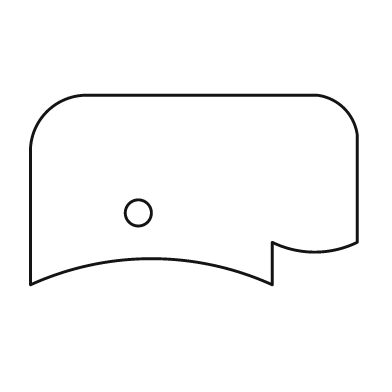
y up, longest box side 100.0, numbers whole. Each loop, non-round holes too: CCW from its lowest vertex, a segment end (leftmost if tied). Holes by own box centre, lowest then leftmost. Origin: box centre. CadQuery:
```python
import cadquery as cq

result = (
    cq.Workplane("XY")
    .moveTo(-50.0, -29.0)
    .threePointArc((-13.0, -21.0), (24.0, -29.0))
    .lineTo(24.0, -16.0)
    .threePointArc((37.0, -19.0), (50.0, -16.0))
    .lineTo(50.0, 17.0)
    .threePointArc((46.0, 25.0), (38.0, 29.0))
    .lineTo(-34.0, 29.0)
    .threePointArc((-45.0, 24.0), (-50.0, 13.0))
    .close()
    .moveTo(-17.0, -7.0)
    .circle(4.0)
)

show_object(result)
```